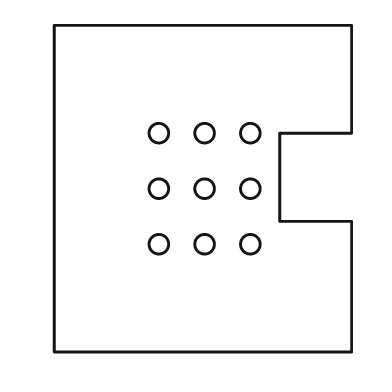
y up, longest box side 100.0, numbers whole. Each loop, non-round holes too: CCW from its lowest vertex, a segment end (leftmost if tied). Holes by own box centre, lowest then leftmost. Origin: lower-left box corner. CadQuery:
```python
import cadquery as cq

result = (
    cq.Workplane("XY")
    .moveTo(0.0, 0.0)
    .lineTo(91.0, 0.0)
    .lineTo(91.0, 40.0)
    .lineTo(69.0, 40.0)
    .lineTo(69.0, 67.0)
    .lineTo(91.0, 67.0)
    .lineTo(91.0, 100.0)
    .lineTo(0.0, 100.0)
    .close()
    .moveTo(32.0, 33.0)
    .circle(3.0)
    .moveTo(46.0, 33.0)
    .circle(3.0)
    .moveTo(60.0, 33.0)
    .circle(3.0)
    .moveTo(32.0, 50.0)
    .circle(3.0)
    .moveTo(46.0, 50.0)
    .circle(3.0)
    .moveTo(60.0, 50.0)
    .circle(3.0)
    .moveTo(32.0, 67.0)
    .circle(3.0)
    .moveTo(46.0, 67.0)
    .circle(3.0)
    .moveTo(60.0, 67.0)
    .circle(3.0)
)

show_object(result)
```